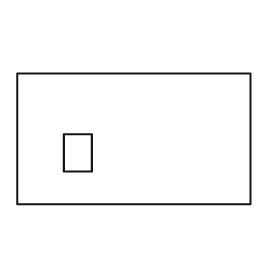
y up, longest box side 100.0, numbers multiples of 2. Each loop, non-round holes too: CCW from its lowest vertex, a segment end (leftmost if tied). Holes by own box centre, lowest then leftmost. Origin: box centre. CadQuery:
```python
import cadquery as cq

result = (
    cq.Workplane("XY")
    .moveTo(-50.0, -28.0)
    .lineTo(50.0, -28.0)
    .lineTo(50.0, 28.0)
    .lineTo(-50.0, 28.0)
    .close()
    .moveTo(-30.0, -14.0)
    .lineTo(-18.0, -14.0)
    .lineTo(-18.0, 2.0)
    .lineTo(-30.0, 2.0)
    .close()
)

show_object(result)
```